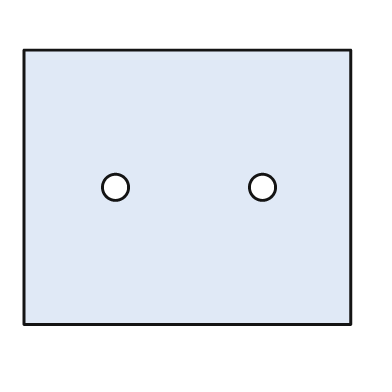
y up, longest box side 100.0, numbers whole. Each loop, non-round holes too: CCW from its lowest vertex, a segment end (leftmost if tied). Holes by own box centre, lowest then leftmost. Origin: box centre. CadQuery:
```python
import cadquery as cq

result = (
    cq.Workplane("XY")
    .moveTo(-50.0, -42.0)
    .lineTo(50.0, -42.0)
    .lineTo(50.0, 42.0)
    .lineTo(-50.0, 42.0)
    .close()
    .moveTo(-22.0, 0.0)
    .circle(4.0)
    .moveTo(23.0, 0.0)
    .circle(4.0)
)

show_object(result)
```